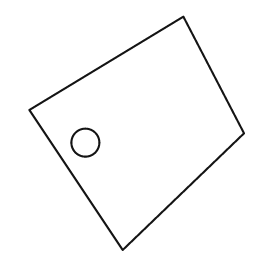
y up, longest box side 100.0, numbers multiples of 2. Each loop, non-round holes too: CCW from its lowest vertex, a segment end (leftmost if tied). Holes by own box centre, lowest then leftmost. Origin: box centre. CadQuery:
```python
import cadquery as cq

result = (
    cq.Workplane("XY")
    .moveTo(-6.0, -50.0)
    .lineTo(46.0, 0.0)
    .lineTo(20.0, 50.0)
    .lineTo(-46.0, 10.0)
    .close()
    .moveTo(-22.0, -4.0)
    .circle(6.0)
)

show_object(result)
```